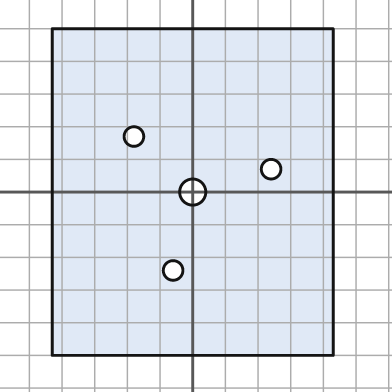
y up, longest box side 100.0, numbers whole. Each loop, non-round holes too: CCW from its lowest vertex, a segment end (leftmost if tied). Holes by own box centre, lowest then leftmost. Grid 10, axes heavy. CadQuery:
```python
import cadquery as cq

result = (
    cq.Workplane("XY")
    .moveTo(-43.0, -50.0)
    .lineTo(43.0, -50.0)
    .lineTo(43.0, 50.0)
    .lineTo(-43.0, 50.0)
    .close()
    .moveTo(-6.0, -24.0)
    .circle(3.0)
    .moveTo(0.0, 0.0)
    .circle(4.0)
    .moveTo(24.0, 7.0)
    .circle(3.0)
    .moveTo(-18.0, 17.0)
    .circle(3.0)
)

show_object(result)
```